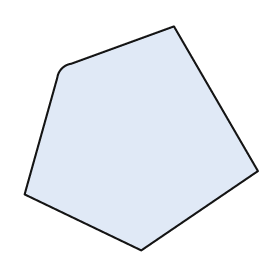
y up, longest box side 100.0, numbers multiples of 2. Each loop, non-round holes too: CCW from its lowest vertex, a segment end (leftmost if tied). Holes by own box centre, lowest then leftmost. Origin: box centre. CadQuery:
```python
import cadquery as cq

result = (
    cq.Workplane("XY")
    .moveTo(0.0, -48.0)
    .lineTo(50.0, -14.0)
    .lineTo(14.0, 48.0)
    .lineTo(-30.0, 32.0)
    .threePointArc((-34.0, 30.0), (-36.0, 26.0))
    .lineTo(-50.0, -24.0)
    .close()
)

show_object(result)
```